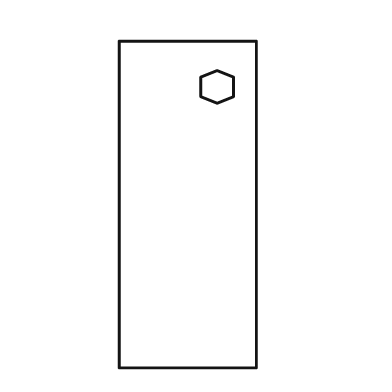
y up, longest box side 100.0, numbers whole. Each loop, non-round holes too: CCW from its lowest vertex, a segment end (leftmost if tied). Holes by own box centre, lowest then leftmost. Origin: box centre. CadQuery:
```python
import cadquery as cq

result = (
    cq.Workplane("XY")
    .moveTo(-21.0, -50.0)
    .lineTo(21.0, -50.0)
    .lineTo(21.0, 50.0)
    .lineTo(-21.0, 50.0)
    .close()
    .moveTo(9.0, 31.0)
    .lineTo(14.0, 33.0)
    .lineTo(14.0, 39.0)
    .lineTo(9.0, 41.0)
    .lineTo(4.0, 39.0)
    .lineTo(4.0, 33.0)
    .close()
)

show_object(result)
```